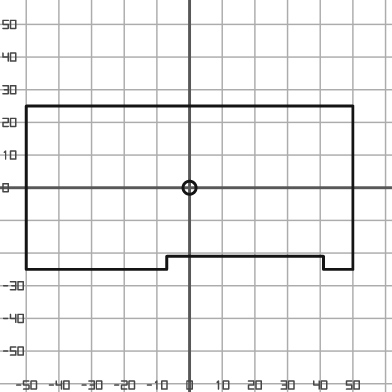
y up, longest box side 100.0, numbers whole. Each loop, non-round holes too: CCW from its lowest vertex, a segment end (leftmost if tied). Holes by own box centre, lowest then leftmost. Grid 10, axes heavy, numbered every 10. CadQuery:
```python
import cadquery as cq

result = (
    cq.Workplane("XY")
    .moveTo(-50.0, -25.0)
    .lineTo(-7.0, -25.0)
    .lineTo(-7.0, -21.0)
    .lineTo(41.0, -21.0)
    .lineTo(41.0, -25.0)
    .lineTo(50.0, -25.0)
    .lineTo(50.0, 25.0)
    .lineTo(-50.0, 25.0)
    .close()
    .moveTo(0.0, 0.0)
    .circle(2.0)
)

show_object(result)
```